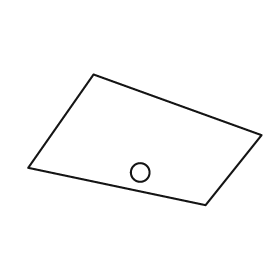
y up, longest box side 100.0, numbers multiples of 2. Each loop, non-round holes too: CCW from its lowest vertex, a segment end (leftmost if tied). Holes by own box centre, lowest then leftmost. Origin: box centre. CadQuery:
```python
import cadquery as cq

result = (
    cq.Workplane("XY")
    .moveTo(26.0, -28.0)
    .lineTo(50.0, 2.0)
    .lineTo(-22.0, 28.0)
    .lineTo(-50.0, -12.0)
    .close()
    .moveTo(-2.0, -14.0)
    .circle(4.0)
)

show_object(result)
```